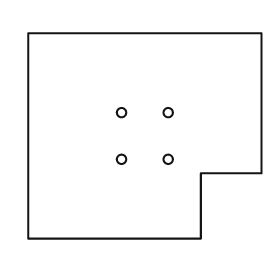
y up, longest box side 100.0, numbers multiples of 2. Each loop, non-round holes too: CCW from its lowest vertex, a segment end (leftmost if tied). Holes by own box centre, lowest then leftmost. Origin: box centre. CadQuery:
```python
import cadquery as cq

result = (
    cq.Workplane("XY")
    .moveTo(-50.0, -44.0)
    .lineTo(24.0, -44.0)
    .lineTo(24.0, -16.0)
    .lineTo(50.0, -16.0)
    .lineTo(50.0, 44.0)
    .lineTo(-50.0, 44.0)
    .close()
    .moveTo(-10.0, -10.0)
    .circle(2.0)
    .moveTo(10.0, -10.0)
    .circle(2.0)
    .moveTo(-10.0, 10.0)
    .circle(2.0)
    .moveTo(10.0, 10.0)
    .circle(2.0)
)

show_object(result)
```